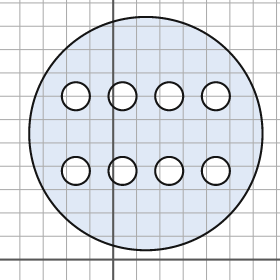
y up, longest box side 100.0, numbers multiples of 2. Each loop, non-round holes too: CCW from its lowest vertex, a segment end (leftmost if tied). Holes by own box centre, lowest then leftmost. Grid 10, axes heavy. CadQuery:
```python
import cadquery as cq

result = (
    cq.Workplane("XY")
    .moveTo(14.0, 54.0)
    .circle(50.0)
    .moveTo(-16.0, 38.0)
    .circle(6.0)
    .moveTo(4.0, 38.0)
    .circle(6.0)
    .moveTo(24.0, 38.0)
    .circle(6.0)
    .moveTo(44.0, 38.0)
    .circle(6.0)
    .moveTo(-16.0, 70.0)
    .circle(6.0)
    .moveTo(4.0, 70.0)
    .circle(6.0)
    .moveTo(24.0, 70.0)
    .circle(6.0)
    .moveTo(44.0, 70.0)
    .circle(6.0)
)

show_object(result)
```